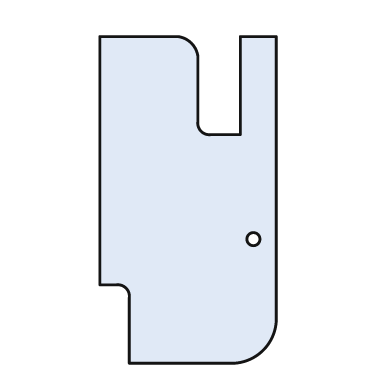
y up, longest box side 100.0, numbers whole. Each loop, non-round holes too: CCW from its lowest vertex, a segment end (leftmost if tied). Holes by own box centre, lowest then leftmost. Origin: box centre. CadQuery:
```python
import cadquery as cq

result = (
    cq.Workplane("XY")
    .moveTo(-18.0, -50.0)
    .lineTo(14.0, -50.0)
    .threePointArc((23.0, -46.0), (27.0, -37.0))
    .lineTo(27.0, 50.0)
    .lineTo(16.0, 50.0)
    .lineTo(16.0, 20.0)
    .lineTo(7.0, 20.0)
    .threePointArc((4.0, 21.0), (3.0, 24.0))
    .lineTo(3.0, 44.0)
    .threePointArc((1.0, 48.0), (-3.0, 50.0))
    .lineTo(-27.0, 50.0)
    .lineTo(-27.0, -26.0)
    .lineTo(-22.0, -26.0)
    .threePointArc((-19.0, -27.0), (-18.0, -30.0))
    .close()
    .moveTo(20.0, -12.0)
    .circle(2.0)
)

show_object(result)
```